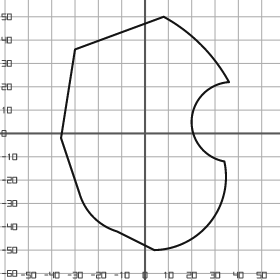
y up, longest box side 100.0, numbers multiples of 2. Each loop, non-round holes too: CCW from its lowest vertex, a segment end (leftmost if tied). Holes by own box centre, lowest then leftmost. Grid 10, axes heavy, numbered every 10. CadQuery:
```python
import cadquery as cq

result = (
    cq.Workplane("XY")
    .moveTo(4.0, -50.0)
    .threePointArc((28.0, -38.0), (34.0, -12.0))
    .threePointArc((20.0, 6.0), (36.0, 22.0))
    .threePointArc((24.0, 38.0), (8.0, 50.0))
    .lineTo(-30.0, 36.0)
    .lineTo(-36.0, -2.0)
    .lineTo(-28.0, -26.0)
    .threePointArc((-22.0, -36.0), (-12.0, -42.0))
    .close()
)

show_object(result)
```